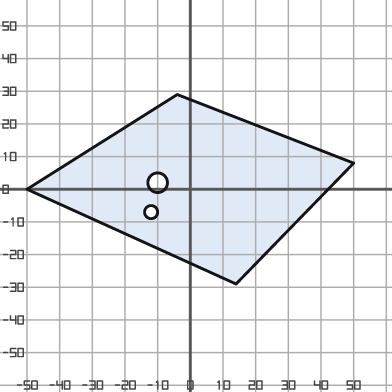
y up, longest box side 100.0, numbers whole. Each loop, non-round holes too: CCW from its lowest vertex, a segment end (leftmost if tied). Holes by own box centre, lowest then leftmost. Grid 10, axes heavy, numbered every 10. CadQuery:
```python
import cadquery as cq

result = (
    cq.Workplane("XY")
    .moveTo(14.0, -29.0)
    .lineTo(50.0, 8.0)
    .lineTo(-4.0, 29.0)
    .lineTo(-50.0, 0.0)
    .close()
    .moveTo(-12.0, -7.0)
    .circle(2.0)
    .moveTo(-10.0, 2.0)
    .circle(3.0)
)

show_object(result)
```